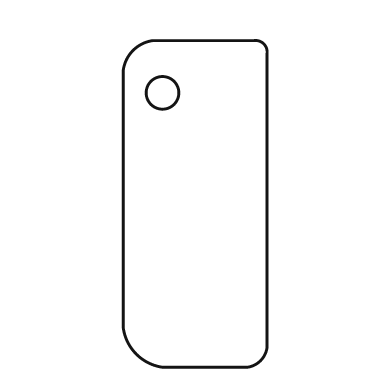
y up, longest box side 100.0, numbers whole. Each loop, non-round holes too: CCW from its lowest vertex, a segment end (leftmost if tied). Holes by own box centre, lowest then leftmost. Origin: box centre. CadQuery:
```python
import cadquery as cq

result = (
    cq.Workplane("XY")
    .moveTo(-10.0, -50.0)
    .lineTo(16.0, -50.0)
    .threePointArc((20.0, -48.0), (22.0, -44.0))
    .lineTo(22.0, 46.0)
    .threePointArc((21.0, 49.0), (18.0, 50.0))
    .lineTo(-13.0, 50.0)
    .threePointArc((-19.0, 47.0), (-22.0, 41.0))
    .lineTo(-22.0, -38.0)
    .threePointArc((-18.0, -46.0), (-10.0, -50.0))
    .close()
    .moveTo(-10.0, 34.0)
    .circle(5.0)
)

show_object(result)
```